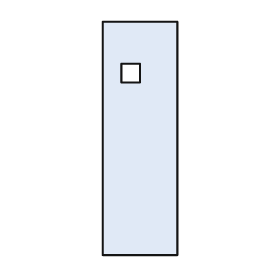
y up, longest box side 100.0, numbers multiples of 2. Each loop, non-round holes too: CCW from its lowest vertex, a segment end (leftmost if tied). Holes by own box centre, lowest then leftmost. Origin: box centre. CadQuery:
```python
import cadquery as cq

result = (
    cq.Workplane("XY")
    .moveTo(-16.0, -50.0)
    .lineTo(16.0, -50.0)
    .lineTo(16.0, 50.0)
    .lineTo(-16.0, 50.0)
    .close()
    .moveTo(-8.0, 24.0)
    .lineTo(0.0, 24.0)
    .lineTo(0.0, 32.0)
    .lineTo(-8.0, 32.0)
    .close()
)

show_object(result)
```